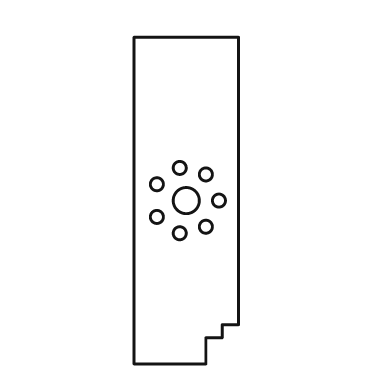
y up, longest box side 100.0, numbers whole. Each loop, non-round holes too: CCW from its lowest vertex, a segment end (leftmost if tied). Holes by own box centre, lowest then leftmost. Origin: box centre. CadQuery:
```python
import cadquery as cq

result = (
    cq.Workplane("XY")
    .moveTo(-16.0, -50.0)
    .lineTo(6.0, -50.0)
    .lineTo(6.0, -42.0)
    .lineTo(11.0, -42.0)
    .lineTo(11.0, -38.0)
    .lineTo(16.0, -38.0)
    .lineTo(16.0, 50.0)
    .lineTo(-16.0, 50.0)
    .close()
    .moveTo(-2.0, -10.0)
    .circle(2.0)
    .moveTo(6.0, -8.0)
    .circle(2.0)
    .moveTo(-9.0, -5.0)
    .circle(2.0)
    .moveTo(0.0, 0.0)
    .circle(4.0)
    .moveTo(10.0, 0.0)
    .circle(2.0)
    .moveTo(-9.0, 5.0)
    .circle(2.0)
    .moveTo(6.0, 8.0)
    .circle(2.0)
    .moveTo(-2.0, 10.0)
    .circle(2.0)
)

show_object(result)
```